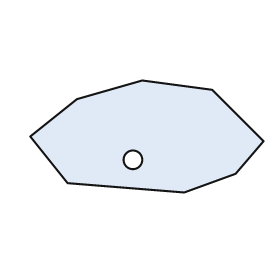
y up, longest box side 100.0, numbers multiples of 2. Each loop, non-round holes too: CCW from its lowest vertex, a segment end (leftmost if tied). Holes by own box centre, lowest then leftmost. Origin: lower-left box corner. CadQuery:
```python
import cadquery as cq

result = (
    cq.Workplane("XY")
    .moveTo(66.0, 0.0)
    .lineTo(88.0, 8.0)
    .lineTo(100.0, 22.0)
    .lineTo(78.0, 44.0)
    .lineTo(48.0, 48.0)
    .lineTo(20.0, 40.0)
    .lineTo(0.0, 24.0)
    .lineTo(16.0, 4.0)
    .close()
    .moveTo(44.0, 14.0)
    .circle(4.0)
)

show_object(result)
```